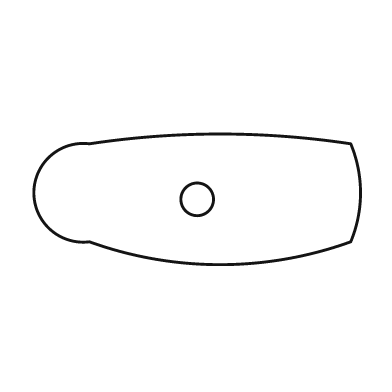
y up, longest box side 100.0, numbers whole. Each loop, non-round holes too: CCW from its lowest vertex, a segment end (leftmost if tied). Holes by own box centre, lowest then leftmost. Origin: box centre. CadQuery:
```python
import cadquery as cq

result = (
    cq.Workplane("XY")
    .moveTo(-33.0, -13.0)
    .threePointArc((7.0, -20.0), (47.0, -13.0))
    .threePointArc((50.0, 2.0), (47.0, 17.0))
    .threePointArc((7.0, 20.0), (-33.0, 17.0))
    .threePointArc((-50.0, 2.0), (-33.0, -13.0))
    .close()
    .moveTo(0.0, 0.0)
    .circle(5.0)
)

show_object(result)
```